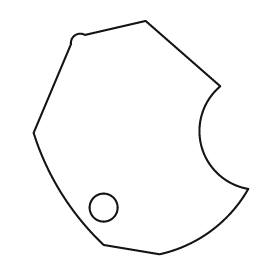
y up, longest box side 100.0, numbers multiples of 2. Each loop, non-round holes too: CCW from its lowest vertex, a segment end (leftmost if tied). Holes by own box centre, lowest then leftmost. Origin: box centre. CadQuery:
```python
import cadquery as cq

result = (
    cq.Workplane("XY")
    .moveTo(8.0, -50.0)
    .threePointArc((30.0, -40.0), (46.0, -22.0))
    .threePointArc((26.0, -4.0), (34.0, 22.0))
    .lineTo(2.0, 50.0)
    .lineTo(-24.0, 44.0)
    .threePointArc((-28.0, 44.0), (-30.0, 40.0))
    .lineTo(-46.0, 2.0)
    .threePointArc((-34.0, -24.0), (-16.0, -46.0))
    .close()
    .moveTo(-16.0, -30.0)
    .circle(6.0)
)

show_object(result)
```